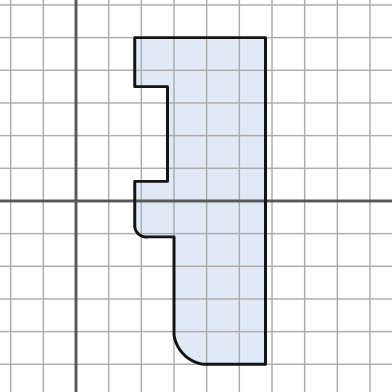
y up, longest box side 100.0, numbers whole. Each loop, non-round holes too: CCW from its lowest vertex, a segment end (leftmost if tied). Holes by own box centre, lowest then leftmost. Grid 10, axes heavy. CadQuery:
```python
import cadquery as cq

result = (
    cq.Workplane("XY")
    .moveTo(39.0, -50.0)
    .lineTo(58.0, -50.0)
    .lineTo(58.0, 50.0)
    .lineTo(18.0, 50.0)
    .lineTo(18.0, 35.0)
    .lineTo(28.0, 35.0)
    .lineTo(28.0, 6.0)
    .lineTo(18.0, 6.0)
    .lineTo(18.0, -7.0)
    .threePointArc((19.0, -10.0), (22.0, -11.0))
    .lineTo(30.0, -11.0)
    .lineTo(30.0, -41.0)
    .threePointArc((33.0, -47.0), (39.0, -50.0))
    .close()
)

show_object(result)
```